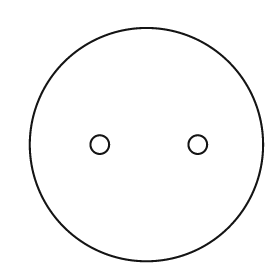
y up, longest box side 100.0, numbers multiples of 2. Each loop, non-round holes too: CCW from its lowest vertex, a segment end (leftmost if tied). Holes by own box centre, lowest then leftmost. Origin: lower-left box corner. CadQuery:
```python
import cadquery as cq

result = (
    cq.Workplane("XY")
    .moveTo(50.0, 50.0)
    .circle(50.0)
    .moveTo(30.0, 50.0)
    .circle(4.0)
    .moveTo(72.0, 50.0)
    .circle(4.0)
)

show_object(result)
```